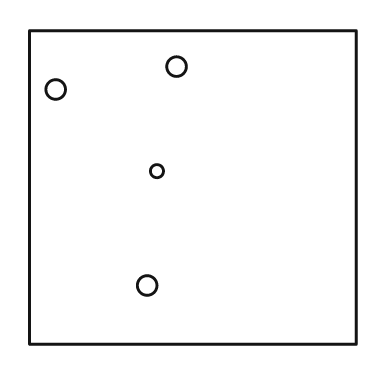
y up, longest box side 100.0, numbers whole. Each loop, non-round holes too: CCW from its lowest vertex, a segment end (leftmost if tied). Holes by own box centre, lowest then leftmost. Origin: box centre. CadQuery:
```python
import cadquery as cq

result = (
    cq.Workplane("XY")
    .moveTo(-50.0, -48.0)
    .lineTo(50.0, -48.0)
    .lineTo(50.0, 48.0)
    .lineTo(-50.0, 48.0)
    .close()
    .moveTo(-14.0, -30.0)
    .circle(3.0)
    .moveTo(-11.0, 5.0)
    .circle(2.0)
    .moveTo(-42.0, 30.0)
    .circle(3.0)
    .moveTo(-5.0, 37.0)
    .circle(3.0)
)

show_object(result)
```